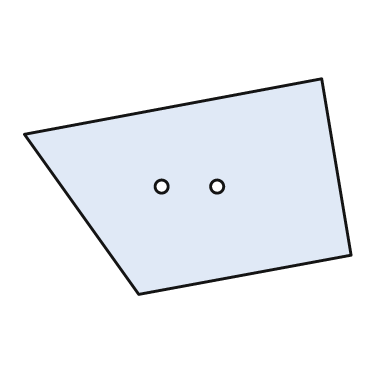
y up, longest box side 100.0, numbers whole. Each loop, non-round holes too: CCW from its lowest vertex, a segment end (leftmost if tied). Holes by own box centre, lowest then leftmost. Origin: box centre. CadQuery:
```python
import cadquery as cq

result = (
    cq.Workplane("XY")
    .moveTo(-15.0, -33.0)
    .lineTo(50.0, -21.0)
    .lineTo(41.0, 33.0)
    .lineTo(-50.0, 16.0)
    .close()
    .moveTo(-8.0, 0.0)
    .circle(2.0)
    .moveTo(9.0, 0.0)
    .circle(2.0)
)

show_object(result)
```